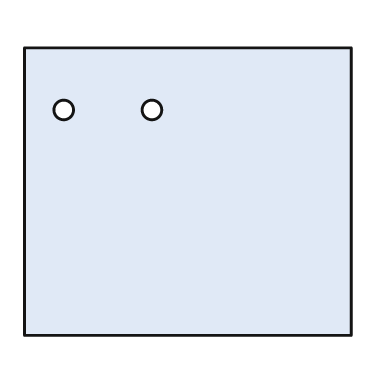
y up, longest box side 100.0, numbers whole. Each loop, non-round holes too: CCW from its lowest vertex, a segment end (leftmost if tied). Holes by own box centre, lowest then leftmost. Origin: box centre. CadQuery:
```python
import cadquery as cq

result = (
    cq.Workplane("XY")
    .moveTo(-50.0, -44.0)
    .lineTo(50.0, -44.0)
    .lineTo(50.0, 44.0)
    .lineTo(-50.0, 44.0)
    .close()
    .moveTo(-38.0, 25.0)
    .circle(3.0)
    .moveTo(-11.0, 25.0)
    .circle(3.0)
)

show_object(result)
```